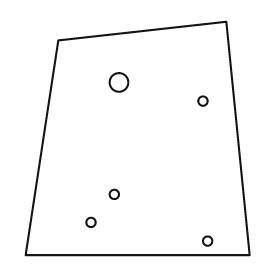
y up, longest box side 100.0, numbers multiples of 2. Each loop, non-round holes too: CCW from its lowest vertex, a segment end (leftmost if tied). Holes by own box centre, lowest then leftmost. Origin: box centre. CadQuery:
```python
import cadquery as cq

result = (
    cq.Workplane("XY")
    .moveTo(-48.0, -50.0)
    .lineTo(48.0, -50.0)
    .lineTo(38.0, 50.0)
    .lineTo(-34.0, 42.0)
    .close()
    .moveTo(30.0, -44.0)
    .circle(2.0)
    .moveTo(-20.0, -36.0)
    .circle(2.0)
    .moveTo(-10.0, -24.0)
    .circle(2.0)
    .moveTo(28.0, 16.0)
    .circle(2.0)
    .moveTo(-8.0, 24.0)
    .circle(4.0)
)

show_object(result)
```